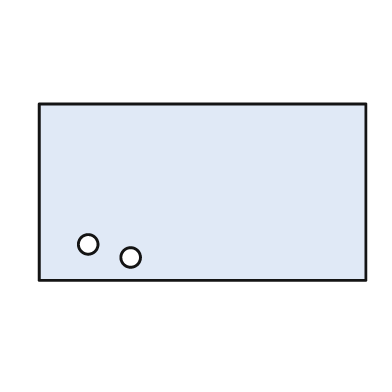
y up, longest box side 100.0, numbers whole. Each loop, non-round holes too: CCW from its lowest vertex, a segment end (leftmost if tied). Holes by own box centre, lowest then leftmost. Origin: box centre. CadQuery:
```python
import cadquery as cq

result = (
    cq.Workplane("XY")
    .moveTo(-50.0, -27.0)
    .lineTo(50.0, -27.0)
    .lineTo(50.0, 27.0)
    .lineTo(-50.0, 27.0)
    .close()
    .moveTo(-22.0, -20.0)
    .circle(3.0)
    .moveTo(-35.0, -16.0)
    .circle(3.0)
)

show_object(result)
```